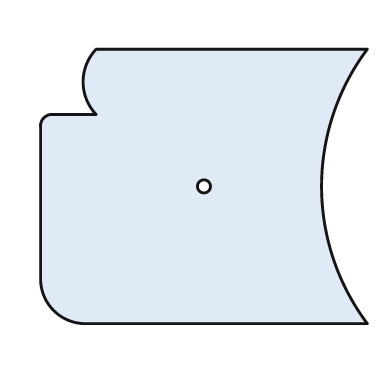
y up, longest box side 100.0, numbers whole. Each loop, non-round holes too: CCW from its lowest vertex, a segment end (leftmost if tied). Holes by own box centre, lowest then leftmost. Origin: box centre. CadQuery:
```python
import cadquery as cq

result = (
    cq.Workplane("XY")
    .moveTo(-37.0, -42.0)
    .lineTo(50.0, -42.0)
    .threePointArc((36.0, 0.0), (50.0, 42.0))
    .lineTo(-33.0, 42.0)
    .threePointArc((-37.0, 32.0), (-33.0, 22.0))
    .lineTo(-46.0, 22.0)
    .threePointArc((-49.0, 21.0), (-50.0, 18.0))
    .lineTo(-50.0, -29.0)
    .threePointArc((-46.0, -38.0), (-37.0, -42.0))
    .close()
    .moveTo(0.0, 0.0)
    .circle(2.0)
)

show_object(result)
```